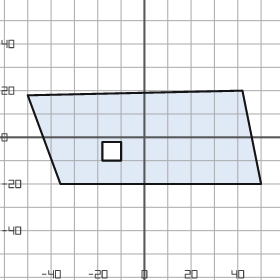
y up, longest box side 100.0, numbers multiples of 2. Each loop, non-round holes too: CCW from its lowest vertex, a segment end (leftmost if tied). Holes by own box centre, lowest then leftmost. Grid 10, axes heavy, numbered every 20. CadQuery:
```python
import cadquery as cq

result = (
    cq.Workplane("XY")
    .moveTo(-36.0, -20.0)
    .lineTo(50.0, -20.0)
    .lineTo(42.0, 20.0)
    .lineTo(-50.0, 18.0)
    .close()
    .moveTo(-18.0, -10.0)
    .lineTo(-10.0, -10.0)
    .lineTo(-10.0, -2.0)
    .lineTo(-18.0, -2.0)
    .close()
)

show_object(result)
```